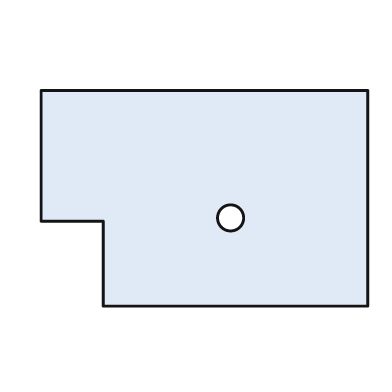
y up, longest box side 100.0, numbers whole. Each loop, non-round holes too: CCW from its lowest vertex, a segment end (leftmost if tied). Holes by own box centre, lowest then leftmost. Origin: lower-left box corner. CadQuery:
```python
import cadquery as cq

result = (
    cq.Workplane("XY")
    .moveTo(19.0, 0.0)
    .lineTo(100.0, 0.0)
    .lineTo(100.0, 66.0)
    .lineTo(0.0, 66.0)
    .lineTo(0.0, 26.0)
    .lineTo(19.0, 26.0)
    .close()
    .moveTo(58.0, 27.0)
    .circle(4.0)
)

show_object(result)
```